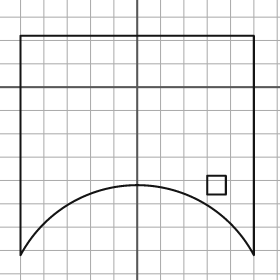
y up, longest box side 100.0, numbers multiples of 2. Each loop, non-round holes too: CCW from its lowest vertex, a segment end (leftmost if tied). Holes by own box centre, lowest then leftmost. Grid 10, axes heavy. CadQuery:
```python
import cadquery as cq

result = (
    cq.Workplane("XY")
    .moveTo(-50.0, -72.0)
    .threePointArc((0.0, -42.0), (50.0, -72.0))
    .lineTo(50.0, 22.0)
    .lineTo(-50.0, 22.0)
    .close()
    .moveTo(30.0, -46.0)
    .lineTo(38.0, -46.0)
    .lineTo(38.0, -38.0)
    .lineTo(30.0, -38.0)
    .close()
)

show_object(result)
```